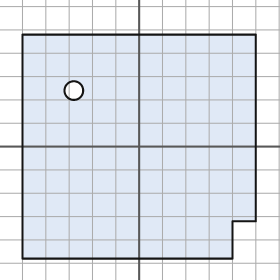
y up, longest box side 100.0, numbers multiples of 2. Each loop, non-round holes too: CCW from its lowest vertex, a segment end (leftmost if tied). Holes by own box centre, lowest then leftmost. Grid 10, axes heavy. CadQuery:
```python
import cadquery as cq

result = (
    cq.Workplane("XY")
    .moveTo(-50.0, -48.0)
    .lineTo(40.0, -48.0)
    .lineTo(40.0, -32.0)
    .lineTo(50.0, -32.0)
    .lineTo(50.0, 48.0)
    .lineTo(-50.0, 48.0)
    .close()
    .moveTo(-28.0, 24.0)
    .circle(4.0)
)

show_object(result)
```